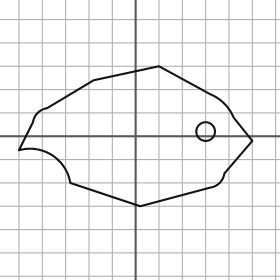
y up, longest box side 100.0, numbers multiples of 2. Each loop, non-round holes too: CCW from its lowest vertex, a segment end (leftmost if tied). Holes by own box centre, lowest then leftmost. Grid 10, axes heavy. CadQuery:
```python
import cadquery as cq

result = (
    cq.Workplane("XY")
    .moveTo(2.0, -30.0)
    .lineTo(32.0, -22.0)
    .threePointArc((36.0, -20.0), (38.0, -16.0))
    .lineTo(50.0, -2.0)
    .lineTo(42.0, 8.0)
    .threePointArc((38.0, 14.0), (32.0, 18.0))
    .lineTo(10.0, 30.0)
    .lineTo(-18.0, 24.0)
    .lineTo(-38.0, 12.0)
    .threePointArc((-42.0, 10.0), (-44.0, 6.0))
    .lineTo(-50.0, -6.0)
    .threePointArc((-36.0, -8.0), (-28.0, -20.0))
    .close()
    .moveTo(30.0, 2.0)
    .circle(4.0)
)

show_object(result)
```